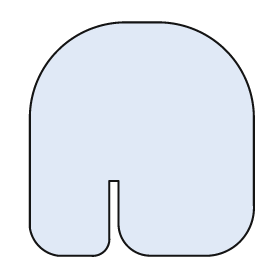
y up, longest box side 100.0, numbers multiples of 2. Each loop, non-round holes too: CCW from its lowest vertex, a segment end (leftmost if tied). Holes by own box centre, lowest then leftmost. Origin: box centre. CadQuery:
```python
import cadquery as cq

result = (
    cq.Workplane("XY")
    .moveTo(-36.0, -50.0)
    .lineTo(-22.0, -50.0)
    .threePointArc((-16.0, -48.0), (-14.0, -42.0))
    .lineTo(-14.0, -18.0)
    .lineTo(-10.0, -18.0)
    .lineTo(-10.0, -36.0)
    .threePointArc((-6.0, -46.0), (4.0, -50.0))
    .lineTo(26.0, -50.0)
    .threePointArc((42.0, -44.0), (48.0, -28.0))
    .lineTo(48.0, 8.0)
    .threePointArc((36.0, 38.0), (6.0, 50.0))
    .lineTo(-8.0, 50.0)
    .threePointArc((-36.0, 38.0), (-48.0, 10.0))
    .lineTo(-48.0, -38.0)
    .threePointArc((-44.0, -46.0), (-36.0, -50.0))
    .close()
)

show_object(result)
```